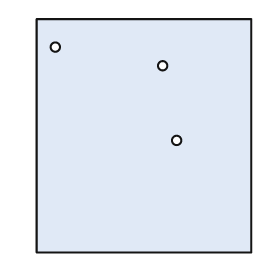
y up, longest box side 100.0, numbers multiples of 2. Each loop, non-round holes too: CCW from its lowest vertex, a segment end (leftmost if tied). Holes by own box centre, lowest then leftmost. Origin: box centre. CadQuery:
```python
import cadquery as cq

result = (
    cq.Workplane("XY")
    .moveTo(-46.0, -50.0)
    .lineTo(46.0, -50.0)
    .lineTo(46.0, 50.0)
    .lineTo(-46.0, 50.0)
    .close()
    .moveTo(14.0, -2.0)
    .circle(2.0)
    .moveTo(8.0, 30.0)
    .circle(2.0)
    .moveTo(-38.0, 38.0)
    .circle(2.0)
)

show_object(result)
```